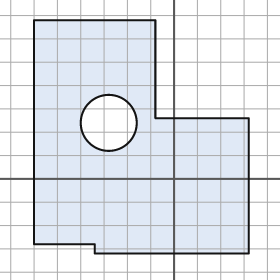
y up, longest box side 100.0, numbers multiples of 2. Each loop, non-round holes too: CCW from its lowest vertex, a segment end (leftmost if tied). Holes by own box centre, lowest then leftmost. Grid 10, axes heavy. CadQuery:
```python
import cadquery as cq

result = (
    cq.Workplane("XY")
    .moveTo(-34.0, -32.0)
    .lineTo(32.0, -32.0)
    .lineTo(32.0, 26.0)
    .lineTo(-8.0, 26.0)
    .lineTo(-8.0, 68.0)
    .lineTo(-60.0, 68.0)
    .lineTo(-60.0, -28.0)
    .lineTo(-34.0, -28.0)
    .close()
    .moveTo(-28.0, 24.0)
    .circle(12.0)
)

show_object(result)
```